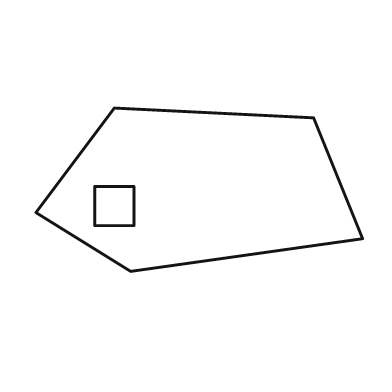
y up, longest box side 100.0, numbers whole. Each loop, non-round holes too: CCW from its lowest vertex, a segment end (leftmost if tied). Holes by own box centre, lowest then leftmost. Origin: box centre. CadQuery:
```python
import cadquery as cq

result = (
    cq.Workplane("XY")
    .moveTo(-21.0, -25.0)
    .lineTo(50.0, -15.0)
    .lineTo(35.0, 22.0)
    .lineTo(-26.0, 25.0)
    .lineTo(-50.0, -7.0)
    .close()
    .moveTo(-32.0, -11.0)
    .lineTo(-20.0, -11.0)
    .lineTo(-20.0, 1.0)
    .lineTo(-32.0, 1.0)
    .close()
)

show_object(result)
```